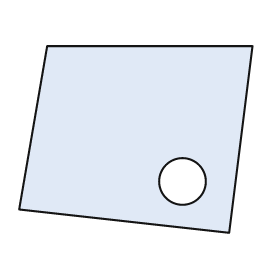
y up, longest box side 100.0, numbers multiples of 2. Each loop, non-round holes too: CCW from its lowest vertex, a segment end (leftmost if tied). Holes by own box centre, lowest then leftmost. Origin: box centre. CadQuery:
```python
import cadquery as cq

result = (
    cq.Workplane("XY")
    .moveTo(40.0, -40.0)
    .lineTo(50.0, 40.0)
    .lineTo(-38.0, 40.0)
    .lineTo(-50.0, -30.0)
    .close()
    .moveTo(20.0, -18.0)
    .circle(10.0)
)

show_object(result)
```